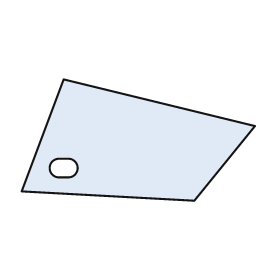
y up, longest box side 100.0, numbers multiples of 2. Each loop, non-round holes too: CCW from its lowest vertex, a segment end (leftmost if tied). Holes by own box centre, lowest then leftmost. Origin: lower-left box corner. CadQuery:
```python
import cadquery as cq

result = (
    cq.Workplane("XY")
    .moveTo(74.0, 0.0)
    .lineTo(100.0, 32.0)
    .lineTo(18.0, 52.0)
    .lineTo(0.0, 4.0)
    .close()
    .moveTo(16.0, 10.0)
    .lineTo(20.0, 10.0)
    .threePointArc((24.0, 14.0), (20.0, 18.0))
    .lineTo(16.0, 18.0)
    .threePointArc((12.0, 14.0), (16.0, 10.0))
    .close()
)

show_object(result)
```